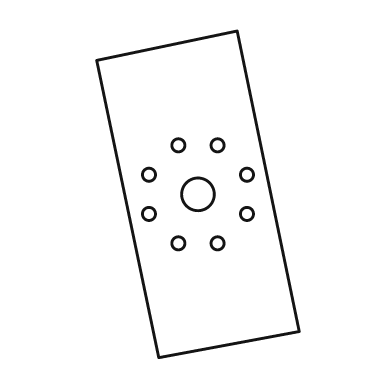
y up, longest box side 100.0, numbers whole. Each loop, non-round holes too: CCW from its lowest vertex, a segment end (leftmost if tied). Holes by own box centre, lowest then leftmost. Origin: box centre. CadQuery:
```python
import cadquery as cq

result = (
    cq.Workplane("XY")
    .moveTo(-12.0, -50.0)
    .lineTo(31.0, -42.0)
    .lineTo(12.0, 50.0)
    .lineTo(-31.0, 41.0)
    .close()
    .moveTo(-6.0, -15.0)
    .circle(2.0)
    .moveTo(6.0, -15.0)
    .circle(2.0)
    .moveTo(-15.0, -6.0)
    .circle(2.0)
    .moveTo(15.0, -6.0)
    .circle(2.0)
    .moveTo(0.0, 0.0)
    .circle(5.0)
    .moveTo(-15.0, 6.0)
    .circle(2.0)
    .moveTo(15.0, 6.0)
    .circle(2.0)
    .moveTo(-6.0, 15.0)
    .circle(2.0)
    .moveTo(6.0, 15.0)
    .circle(2.0)
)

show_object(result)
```